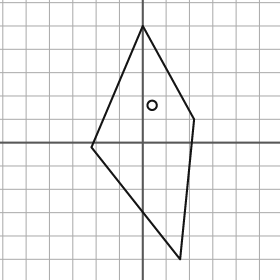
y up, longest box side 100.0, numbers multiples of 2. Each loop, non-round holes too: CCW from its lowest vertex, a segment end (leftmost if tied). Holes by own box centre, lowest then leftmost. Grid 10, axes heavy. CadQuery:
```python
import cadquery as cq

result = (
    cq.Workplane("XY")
    .moveTo(16.0, -50.0)
    .lineTo(22.0, 10.0)
    .lineTo(0.0, 50.0)
    .lineTo(-22.0, -2.0)
    .close()
    .moveTo(4.0, 16.0)
    .circle(2.0)
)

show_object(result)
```